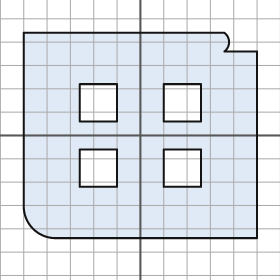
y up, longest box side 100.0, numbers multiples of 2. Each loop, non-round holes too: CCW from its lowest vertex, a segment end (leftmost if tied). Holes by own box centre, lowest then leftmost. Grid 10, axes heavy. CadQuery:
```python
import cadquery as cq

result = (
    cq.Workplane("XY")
    .moveTo(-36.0, -44.0)
    .lineTo(50.0, -44.0)
    .lineTo(50.0, 36.0)
    .lineTo(36.0, 36.0)
    .threePointArc((38.0, 40.0), (36.0, 44.0))
    .lineTo(-50.0, 44.0)
    .lineTo(-50.0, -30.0)
    .threePointArc((-46.0, -40.0), (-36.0, -44.0))
    .close()
    .moveTo(-26.0, -22.0)
    .lineTo(-10.0, -22.0)
    .lineTo(-10.0, -6.0)
    .lineTo(-26.0, -6.0)
    .close()
    .moveTo(10.0, -22.0)
    .lineTo(26.0, -22.0)
    .lineTo(26.0, -6.0)
    .lineTo(10.0, -6.0)
    .close()
    .moveTo(-26.0, 6.0)
    .lineTo(-10.0, 6.0)
    .lineTo(-10.0, 22.0)
    .lineTo(-26.0, 22.0)
    .close()
    .moveTo(10.0, 6.0)
    .lineTo(26.0, 6.0)
    .lineTo(26.0, 22.0)
    .lineTo(10.0, 22.0)
    .close()
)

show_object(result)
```